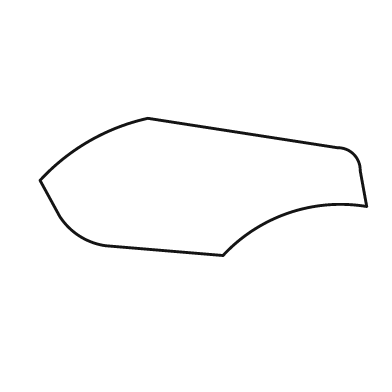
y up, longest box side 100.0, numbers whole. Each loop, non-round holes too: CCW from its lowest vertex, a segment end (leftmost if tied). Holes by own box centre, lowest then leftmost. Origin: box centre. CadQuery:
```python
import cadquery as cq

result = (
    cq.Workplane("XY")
    .moveTo(6.0, -21.0)
    .threePointArc((26.0, -8.0), (50.0, -6.0))
    .lineTo(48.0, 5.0)
    .threePointArc((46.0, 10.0), (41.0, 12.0))
    .lineTo(-17.0, 21.0)
    .threePointArc((-35.0, 14.0), (-50.0, 2.0))
    .lineTo(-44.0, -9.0)
    .threePointArc((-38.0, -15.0), (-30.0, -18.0))
    .close()
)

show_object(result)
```